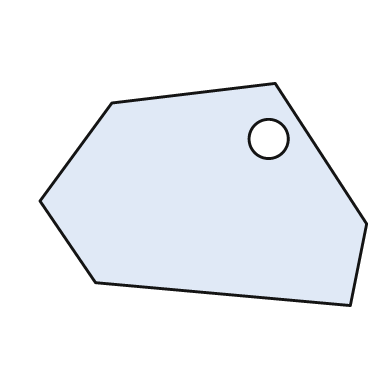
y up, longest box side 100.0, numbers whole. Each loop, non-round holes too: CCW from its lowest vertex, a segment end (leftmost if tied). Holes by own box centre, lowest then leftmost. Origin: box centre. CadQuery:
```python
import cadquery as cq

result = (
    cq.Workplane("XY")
    .moveTo(45.0, -34.0)
    .lineTo(50.0, -9.0)
    .lineTo(22.0, 34.0)
    .lineTo(-28.0, 28.0)
    .lineTo(-50.0, -2.0)
    .lineTo(-33.0, -27.0)
    .close()
    .moveTo(20.0, 17.0)
    .circle(6.0)
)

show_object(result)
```